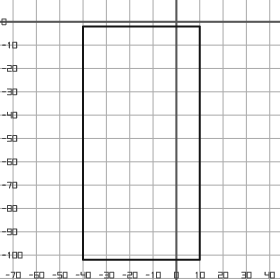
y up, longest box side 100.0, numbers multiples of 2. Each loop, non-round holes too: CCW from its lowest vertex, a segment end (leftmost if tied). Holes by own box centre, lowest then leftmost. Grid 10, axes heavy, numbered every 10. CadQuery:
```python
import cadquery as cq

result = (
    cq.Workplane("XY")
    .moveTo(-40.0, -102.0)
    .lineTo(10.0, -102.0)
    .lineTo(10.0, -2.0)
    .lineTo(-40.0, -2.0)
    .close()
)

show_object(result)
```